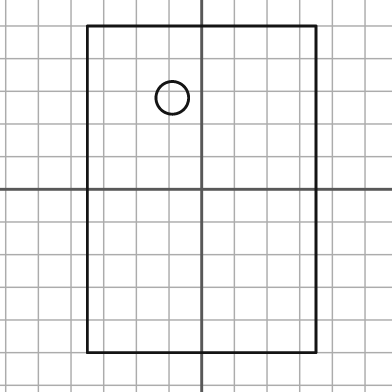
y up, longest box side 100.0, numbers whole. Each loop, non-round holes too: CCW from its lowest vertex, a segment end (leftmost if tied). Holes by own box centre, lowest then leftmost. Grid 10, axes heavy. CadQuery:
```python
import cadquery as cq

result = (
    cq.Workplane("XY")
    .moveTo(-35.0, -50.0)
    .lineTo(35.0, -50.0)
    .lineTo(35.0, 50.0)
    .lineTo(-35.0, 50.0)
    .close()
    .moveTo(-9.0, 28.0)
    .circle(5.0)
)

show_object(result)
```